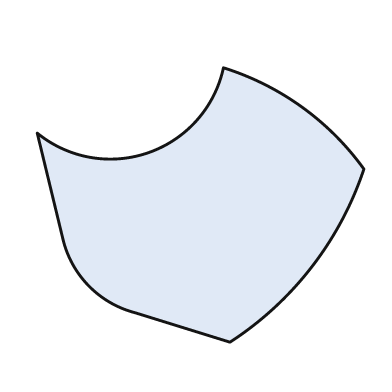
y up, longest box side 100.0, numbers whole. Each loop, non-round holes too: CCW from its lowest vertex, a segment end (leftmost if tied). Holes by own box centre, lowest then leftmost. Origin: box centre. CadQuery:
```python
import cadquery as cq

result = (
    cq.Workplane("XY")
    .moveTo(9.0, -42.0)
    .threePointArc((34.0, -19.0), (50.0, 11.0))
    .threePointArc((31.0, 30.0), (7.0, 42.0))
    .threePointArc((-16.0, 16.0), (-50.0, 22.0))
    .lineTo(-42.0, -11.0)
    .threePointArc((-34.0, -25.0), (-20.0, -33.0))
    .close()
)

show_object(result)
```